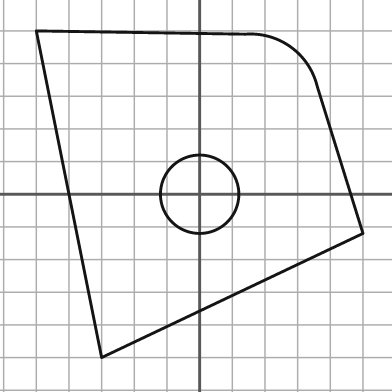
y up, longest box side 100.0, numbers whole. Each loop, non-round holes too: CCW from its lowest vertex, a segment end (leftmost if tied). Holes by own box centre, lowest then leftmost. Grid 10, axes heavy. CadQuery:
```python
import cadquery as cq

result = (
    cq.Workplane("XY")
    .moveTo(-30.0, -50.0)
    .lineTo(50.0, -12.0)
    .lineTo(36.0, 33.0)
    .threePointArc((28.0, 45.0), (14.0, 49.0))
    .lineTo(-50.0, 50.0)
    .close()
    .moveTo(0.0, 0.0)
    .circle(12.0)
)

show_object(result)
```